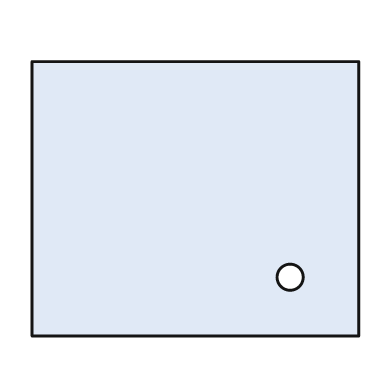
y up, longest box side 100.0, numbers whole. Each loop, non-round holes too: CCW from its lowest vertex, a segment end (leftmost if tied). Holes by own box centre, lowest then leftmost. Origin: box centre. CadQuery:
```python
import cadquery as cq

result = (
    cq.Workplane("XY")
    .moveTo(-50.0, -42.0)
    .lineTo(50.0, -42.0)
    .lineTo(50.0, 42.0)
    .lineTo(-50.0, 42.0)
    .close()
    .moveTo(29.0, -24.0)
    .circle(4.0)
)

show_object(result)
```